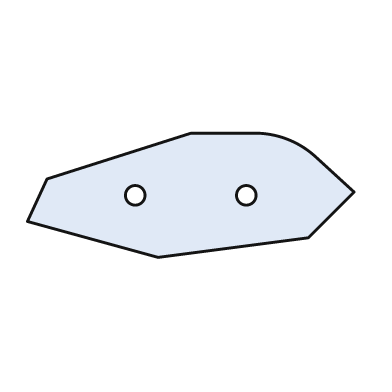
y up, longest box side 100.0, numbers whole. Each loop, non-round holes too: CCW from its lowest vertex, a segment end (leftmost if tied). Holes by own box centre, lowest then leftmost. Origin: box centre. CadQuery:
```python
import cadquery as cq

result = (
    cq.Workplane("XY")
    .moveTo(-10.0, -19.0)
    .lineTo(36.0, -13.0)
    .lineTo(50.0, 1.0)
    .lineTo(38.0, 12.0)
    .threePointArc((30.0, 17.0), (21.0, 19.0))
    .lineTo(0.0, 19.0)
    .lineTo(-44.0, 5.0)
    .lineTo(-50.0, -8.0)
    .close()
    .moveTo(-17.0, 0.0)
    .circle(3.0)
    .moveTo(17.0, 0.0)
    .circle(3.0)
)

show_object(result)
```